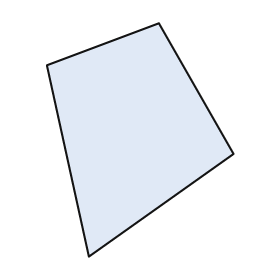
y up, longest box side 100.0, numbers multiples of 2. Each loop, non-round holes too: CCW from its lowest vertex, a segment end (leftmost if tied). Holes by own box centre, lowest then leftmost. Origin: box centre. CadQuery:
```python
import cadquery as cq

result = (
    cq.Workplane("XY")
    .moveTo(-22.0, -50.0)
    .lineTo(40.0, -6.0)
    .lineTo(8.0, 50.0)
    .lineTo(-40.0, 32.0)
    .close()
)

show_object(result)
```